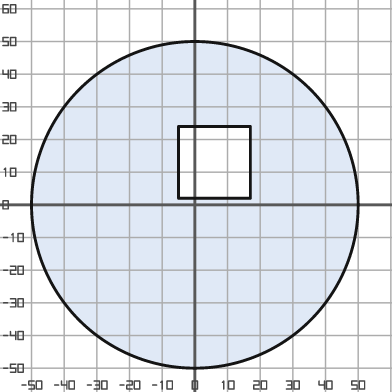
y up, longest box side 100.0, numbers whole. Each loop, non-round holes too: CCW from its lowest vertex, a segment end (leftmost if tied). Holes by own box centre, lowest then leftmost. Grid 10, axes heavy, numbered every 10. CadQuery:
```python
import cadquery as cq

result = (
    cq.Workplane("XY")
    .moveTo(0.0, 0.0)
    .circle(50.0)
    .moveTo(-5.0, 2.0)
    .lineTo(17.0, 2.0)
    .lineTo(17.0, 24.0)
    .lineTo(-5.0, 24.0)
    .close()
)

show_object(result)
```